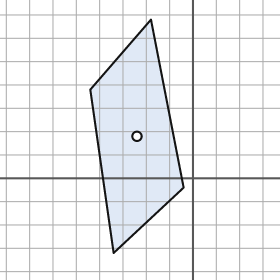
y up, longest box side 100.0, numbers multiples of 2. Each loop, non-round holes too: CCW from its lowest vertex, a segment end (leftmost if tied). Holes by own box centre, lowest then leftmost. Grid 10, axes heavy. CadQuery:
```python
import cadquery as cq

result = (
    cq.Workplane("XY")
    .moveTo(-34.0, -32.0)
    .lineTo(-4.0, -4.0)
    .lineTo(-18.0, 68.0)
    .lineTo(-44.0, 38.0)
    .close()
    .moveTo(-24.0, 18.0)
    .circle(2.0)
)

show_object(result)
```